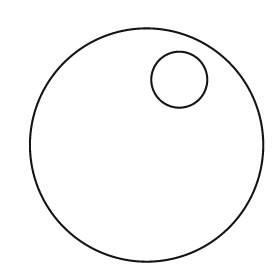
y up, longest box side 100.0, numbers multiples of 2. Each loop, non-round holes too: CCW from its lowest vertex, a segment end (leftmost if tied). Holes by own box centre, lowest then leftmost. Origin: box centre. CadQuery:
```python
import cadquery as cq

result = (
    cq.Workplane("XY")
    .moveTo(0.0, 0.0)
    .circle(50.0)
    .moveTo(14.0, 28.0)
    .circle(12.0)
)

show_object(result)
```